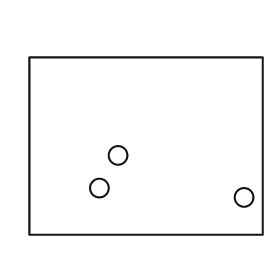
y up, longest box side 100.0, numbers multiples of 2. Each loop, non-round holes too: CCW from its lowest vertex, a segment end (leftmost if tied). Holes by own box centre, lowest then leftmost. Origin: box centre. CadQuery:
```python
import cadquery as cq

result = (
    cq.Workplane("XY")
    .moveTo(-50.0, -38.0)
    .lineTo(50.0, -38.0)
    .lineTo(50.0, 38.0)
    .lineTo(-50.0, 38.0)
    .close()
    .moveTo(42.0, -22.0)
    .circle(4.0)
    .moveTo(-20.0, -18.0)
    .circle(4.0)
    .moveTo(-12.0, -4.0)
    .circle(4.0)
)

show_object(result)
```